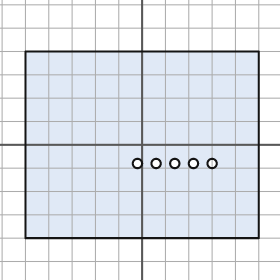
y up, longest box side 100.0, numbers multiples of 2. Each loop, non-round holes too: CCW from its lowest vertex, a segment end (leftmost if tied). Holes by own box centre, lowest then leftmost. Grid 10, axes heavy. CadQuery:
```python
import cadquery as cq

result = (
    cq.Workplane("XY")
    .moveTo(-50.0, -40.0)
    .lineTo(50.0, -40.0)
    .lineTo(50.0, 40.0)
    .lineTo(-50.0, 40.0)
    .close()
    .moveTo(-2.0, -8.0)
    .circle(2.0)
    .moveTo(6.0, -8.0)
    .circle(2.0)
    .moveTo(14.0, -8.0)
    .circle(2.0)
    .moveTo(22.0, -8.0)
    .circle(2.0)
    .moveTo(30.0, -8.0)
    .circle(2.0)
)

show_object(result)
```